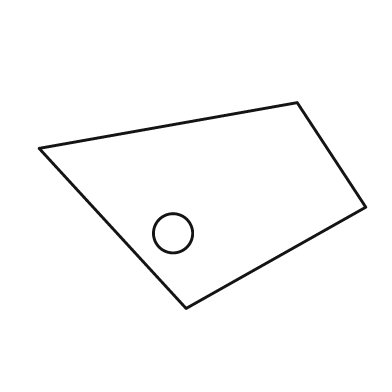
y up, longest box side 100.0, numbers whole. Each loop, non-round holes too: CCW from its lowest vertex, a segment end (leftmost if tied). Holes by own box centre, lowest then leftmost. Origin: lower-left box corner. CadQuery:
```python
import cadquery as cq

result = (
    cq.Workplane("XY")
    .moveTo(45.0, 0.0)
    .lineTo(100.0, 31.0)
    .lineTo(79.0, 63.0)
    .lineTo(0.0, 49.0)
    .close()
    .moveTo(41.0, 23.0)
    .circle(6.0)
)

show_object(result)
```